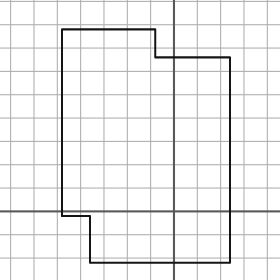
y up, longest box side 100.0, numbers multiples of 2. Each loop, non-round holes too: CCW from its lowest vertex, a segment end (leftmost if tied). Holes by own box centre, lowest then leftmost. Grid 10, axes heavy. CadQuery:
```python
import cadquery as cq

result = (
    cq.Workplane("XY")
    .moveTo(-36.0, -22.0)
    .lineTo(24.0, -22.0)
    .lineTo(24.0, 66.0)
    .lineTo(-8.0, 66.0)
    .lineTo(-8.0, 78.0)
    .lineTo(-48.0, 78.0)
    .lineTo(-48.0, -2.0)
    .lineTo(-36.0, -2.0)
    .close()
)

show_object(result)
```